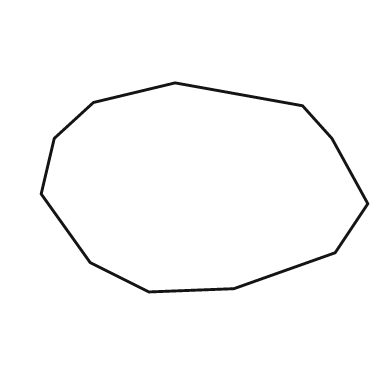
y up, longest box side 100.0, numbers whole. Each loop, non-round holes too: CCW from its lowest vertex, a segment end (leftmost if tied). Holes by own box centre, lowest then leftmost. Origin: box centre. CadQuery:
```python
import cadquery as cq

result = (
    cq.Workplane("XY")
    .moveTo(-17.0, -32.0)
    .lineTo(9.0, -31.0)
    .lineTo(40.0, -20.0)
    .lineTo(50.0, -5.0)
    .lineTo(39.0, 15.0)
    .lineTo(30.0, 25.0)
    .lineTo(-9.0, 32.0)
    .lineTo(-34.0, 26.0)
    .lineTo(-46.0, 15.0)
    .lineTo(-50.0, -2.0)
    .lineTo(-35.0, -23.0)
    .close()
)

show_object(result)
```